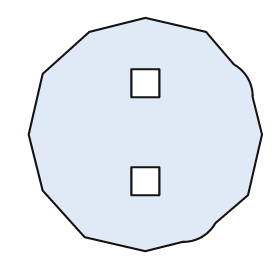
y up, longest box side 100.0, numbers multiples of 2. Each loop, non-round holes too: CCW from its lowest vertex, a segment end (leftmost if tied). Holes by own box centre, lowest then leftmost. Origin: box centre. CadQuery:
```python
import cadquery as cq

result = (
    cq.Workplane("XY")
    .moveTo(0.0, -50.0)
    .lineTo(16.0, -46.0)
    .threePointArc((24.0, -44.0), (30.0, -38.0))
    .lineTo(44.0, -26.0)
    .lineTo(50.0, 0.0)
    .lineTo(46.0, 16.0)
    .threePointArc((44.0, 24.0), (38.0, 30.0))
    .lineTo(26.0, 44.0)
    .lineTo(0.0, 50.0)
    .lineTo(-24.0, 44.0)
    .lineTo(-44.0, 26.0)
    .lineTo(-50.0, 0.0)
    .lineTo(-44.0, -24.0)
    .lineTo(-26.0, -44.0)
    .close()
    .moveTo(-6.0, -26.0)
    .lineTo(6.0, -26.0)
    .lineTo(6.0, -14.0)
    .lineTo(-6.0, -14.0)
    .close()
    .moveTo(-6.0, 16.0)
    .lineTo(6.0, 16.0)
    .lineTo(6.0, 28.0)
    .lineTo(-6.0, 28.0)
    .close()
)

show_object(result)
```